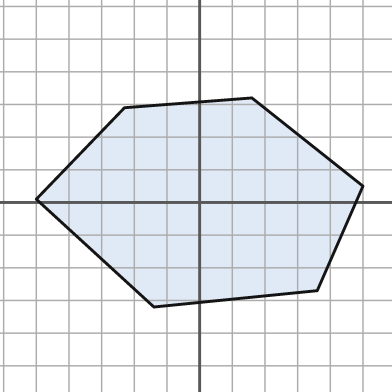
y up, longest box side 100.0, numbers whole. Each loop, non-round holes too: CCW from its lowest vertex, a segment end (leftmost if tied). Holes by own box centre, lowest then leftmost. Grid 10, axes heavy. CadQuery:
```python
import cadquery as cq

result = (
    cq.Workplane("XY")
    .moveTo(-14.0, -32.0)
    .lineTo(36.0, -27.0)
    .lineTo(50.0, 5.0)
    .lineTo(16.0, 32.0)
    .lineTo(-23.0, 29.0)
    .lineTo(-50.0, 1.0)
    .close()
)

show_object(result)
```